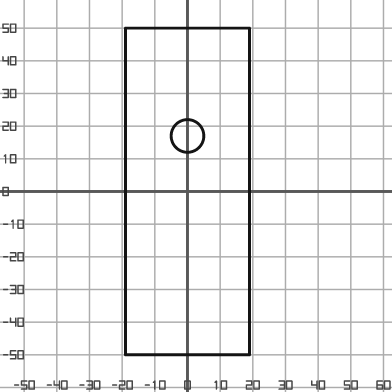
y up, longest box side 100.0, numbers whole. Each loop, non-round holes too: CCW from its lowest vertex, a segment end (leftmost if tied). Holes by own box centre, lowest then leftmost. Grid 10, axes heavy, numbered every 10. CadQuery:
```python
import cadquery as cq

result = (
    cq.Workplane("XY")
    .moveTo(-19.0, -50.0)
    .lineTo(19.0, -50.0)
    .lineTo(19.0, 50.0)
    .lineTo(-19.0, 50.0)
    .close()
    .moveTo(0.0, 17.0)
    .circle(5.0)
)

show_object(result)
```